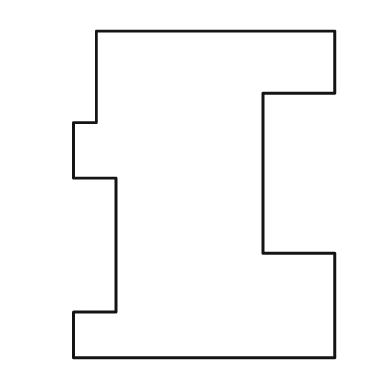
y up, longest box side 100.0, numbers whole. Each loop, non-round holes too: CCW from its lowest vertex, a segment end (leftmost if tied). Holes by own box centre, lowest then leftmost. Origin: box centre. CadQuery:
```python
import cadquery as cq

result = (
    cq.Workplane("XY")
    .moveTo(-40.0, -50.0)
    .lineTo(40.0, -50.0)
    .lineTo(40.0, -18.0)
    .lineTo(18.0, -18.0)
    .lineTo(18.0, 31.0)
    .lineTo(40.0, 31.0)
    .lineTo(40.0, 50.0)
    .lineTo(-33.0, 50.0)
    .lineTo(-33.0, 22.0)
    .lineTo(-40.0, 22.0)
    .lineTo(-40.0, 5.0)
    .lineTo(-27.0, 5.0)
    .lineTo(-27.0, -36.0)
    .lineTo(-40.0, -36.0)
    .close()
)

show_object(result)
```